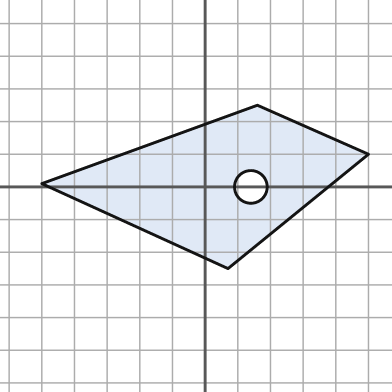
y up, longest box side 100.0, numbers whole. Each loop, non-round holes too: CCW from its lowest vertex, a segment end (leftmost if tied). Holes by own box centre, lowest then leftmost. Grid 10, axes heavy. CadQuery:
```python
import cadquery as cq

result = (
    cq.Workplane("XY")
    .moveTo(7.0, -25.0)
    .lineTo(50.0, 10.0)
    .lineTo(16.0, 25.0)
    .lineTo(-50.0, 1.0)
    .close()
    .moveTo(14.0, 0.0)
    .circle(5.0)
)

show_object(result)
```